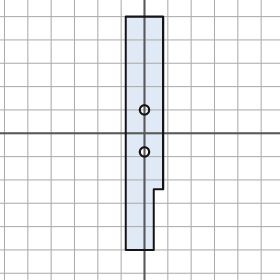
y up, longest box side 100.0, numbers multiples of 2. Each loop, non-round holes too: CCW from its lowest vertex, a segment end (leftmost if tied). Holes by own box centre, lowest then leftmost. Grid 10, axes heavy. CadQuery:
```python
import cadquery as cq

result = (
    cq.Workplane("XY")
    .moveTo(-8.0, -50.0)
    .lineTo(4.0, -50.0)
    .lineTo(4.0, -24.0)
    .lineTo(8.0, -24.0)
    .lineTo(8.0, 50.0)
    .lineTo(-8.0, 50.0)
    .close()
    .moveTo(0.0, -8.0)
    .circle(2.0)
    .moveTo(0.0, 10.0)
    .circle(2.0)
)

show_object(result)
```